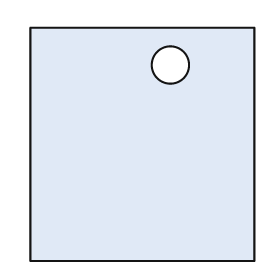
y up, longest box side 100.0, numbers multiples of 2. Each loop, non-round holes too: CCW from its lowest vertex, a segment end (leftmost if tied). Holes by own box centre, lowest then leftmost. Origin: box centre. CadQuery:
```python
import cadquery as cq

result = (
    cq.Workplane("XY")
    .moveTo(-48.0, -50.0)
    .lineTo(48.0, -50.0)
    .lineTo(48.0, 50.0)
    .lineTo(-48.0, 50.0)
    .close()
    .moveTo(12.0, 34.0)
    .circle(8.0)
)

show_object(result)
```